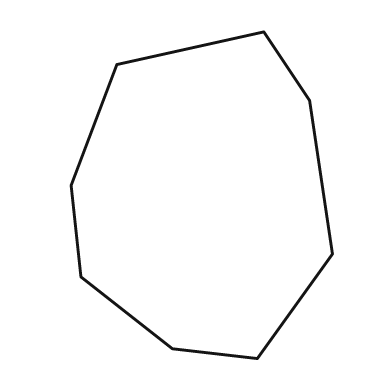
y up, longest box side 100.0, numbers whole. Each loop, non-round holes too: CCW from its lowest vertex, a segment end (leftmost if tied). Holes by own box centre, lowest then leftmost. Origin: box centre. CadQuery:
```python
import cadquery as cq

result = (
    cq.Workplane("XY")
    .moveTo(17.0, -50.0)
    .lineTo(40.0, -18.0)
    .lineTo(33.0, 29.0)
    .lineTo(19.0, 50.0)
    .lineTo(-26.0, 40.0)
    .lineTo(-40.0, 3.0)
    .lineTo(-37.0, -25.0)
    .lineTo(-9.0, -47.0)
    .close()
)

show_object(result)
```